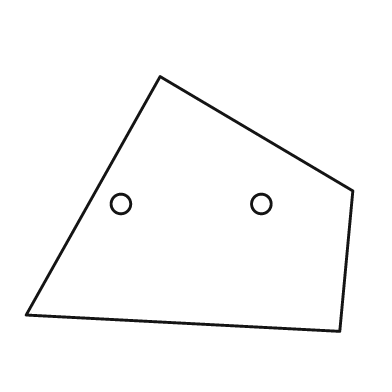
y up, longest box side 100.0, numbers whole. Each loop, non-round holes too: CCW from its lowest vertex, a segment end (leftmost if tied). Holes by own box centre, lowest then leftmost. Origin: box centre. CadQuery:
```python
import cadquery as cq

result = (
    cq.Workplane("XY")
    .moveTo(46.0, -39.0)
    .lineTo(50.0, 4.0)
    .lineTo(-9.0, 39.0)
    .lineTo(-50.0, -34.0)
    .close()
    .moveTo(-21.0, 0.0)
    .circle(3.0)
    .moveTo(22.0, 0.0)
    .circle(3.0)
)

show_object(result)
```